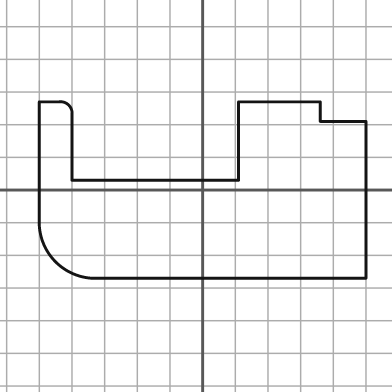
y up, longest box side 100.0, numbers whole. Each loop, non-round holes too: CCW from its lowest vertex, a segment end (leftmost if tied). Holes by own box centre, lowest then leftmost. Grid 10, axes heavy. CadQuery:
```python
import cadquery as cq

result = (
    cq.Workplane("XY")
    .moveTo(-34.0, -27.0)
    .lineTo(50.0, -27.0)
    .lineTo(50.0, 21.0)
    .lineTo(36.0, 21.0)
    .lineTo(36.0, 27.0)
    .lineTo(11.0, 27.0)
    .lineTo(11.0, 3.0)
    .lineTo(-40.0, 3.0)
    .lineTo(-40.0, 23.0)
    .threePointArc((-41.0, 26.0), (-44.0, 27.0))
    .lineTo(-50.0, 27.0)
    .lineTo(-50.0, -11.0)
    .threePointArc((-45.0, -22.0), (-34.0, -27.0))
    .close()
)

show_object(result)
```